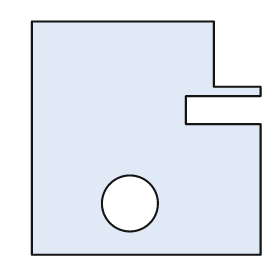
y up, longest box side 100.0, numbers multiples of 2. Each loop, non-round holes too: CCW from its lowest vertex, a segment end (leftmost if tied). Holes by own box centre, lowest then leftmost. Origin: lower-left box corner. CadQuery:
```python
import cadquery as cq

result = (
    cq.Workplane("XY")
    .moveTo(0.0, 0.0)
    .lineTo(98.0, 0.0)
    .lineTo(98.0, 56.0)
    .lineTo(66.0, 56.0)
    .lineTo(66.0, 68.0)
    .lineTo(98.0, 68.0)
    .lineTo(98.0, 72.0)
    .lineTo(78.0, 72.0)
    .lineTo(78.0, 100.0)
    .lineTo(0.0, 100.0)
    .close()
    .moveTo(42.0, 22.0)
    .circle(12.0)
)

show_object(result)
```